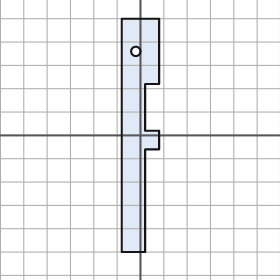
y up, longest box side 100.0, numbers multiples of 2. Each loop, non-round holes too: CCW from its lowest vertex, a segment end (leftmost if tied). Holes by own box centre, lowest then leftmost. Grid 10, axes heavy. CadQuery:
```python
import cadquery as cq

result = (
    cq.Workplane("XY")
    .moveTo(-8.0, -50.0)
    .lineTo(2.0, -50.0)
    .lineTo(2.0, -6.0)
    .lineTo(8.0, -6.0)
    .lineTo(8.0, 2.0)
    .lineTo(2.0, 2.0)
    .lineTo(2.0, 22.0)
    .lineTo(8.0, 22.0)
    .lineTo(8.0, 50.0)
    .lineTo(-8.0, 50.0)
    .close()
    .moveTo(-2.0, 36.0)
    .circle(2.0)
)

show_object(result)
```